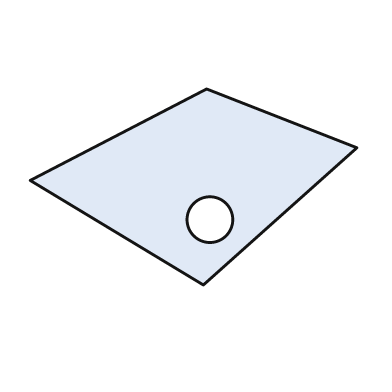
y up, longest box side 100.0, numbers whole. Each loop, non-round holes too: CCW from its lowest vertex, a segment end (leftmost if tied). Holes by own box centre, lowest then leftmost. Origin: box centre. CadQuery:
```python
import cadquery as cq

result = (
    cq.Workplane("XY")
    .moveTo(3.0, -30.0)
    .lineTo(50.0, 12.0)
    .lineTo(4.0, 30.0)
    .lineTo(-50.0, 2.0)
    .close()
    .moveTo(5.0, -10.0)
    .circle(7.0)
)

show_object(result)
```